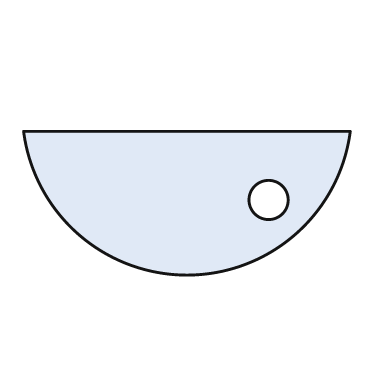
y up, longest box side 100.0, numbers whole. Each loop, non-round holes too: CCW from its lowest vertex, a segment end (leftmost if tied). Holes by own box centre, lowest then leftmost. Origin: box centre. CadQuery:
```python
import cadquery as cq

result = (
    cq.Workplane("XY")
    .moveTo(-50.0, 22.0)
    .threePointArc((0.0, -22.0), (50.0, 22.0))
    .close()
    .moveTo(25.0, 1.0)
    .circle(6.0)
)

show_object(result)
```